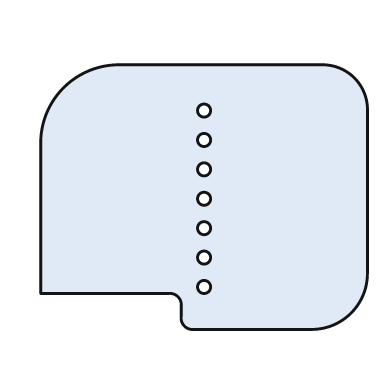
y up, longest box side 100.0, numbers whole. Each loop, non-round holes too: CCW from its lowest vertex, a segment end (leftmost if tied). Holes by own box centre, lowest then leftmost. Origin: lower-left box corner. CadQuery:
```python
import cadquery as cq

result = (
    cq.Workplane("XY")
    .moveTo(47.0, 0.0)
    .lineTo(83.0, 0.0)
    .threePointArc((95.0, 5.0), (100.0, 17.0))
    .lineTo(100.0, 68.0)
    .threePointArc((96.0, 77.0), (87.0, 81.0))
    .lineTo(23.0, 81.0)
    .threePointArc((7.0, 74.0), (0.0, 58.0))
    .lineTo(0.0, 11.0)
    .lineTo(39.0, 11.0)
    .threePointArc((42.0, 10.0), (43.0, 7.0))
    .lineTo(43.0, 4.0)
    .threePointArc((44.0, 1.0), (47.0, 0.0))
    .close()
    .moveTo(50.0, 13.0)
    .circle(2.0)
    .moveTo(50.0, 22.0)
    .circle(2.0)
    .moveTo(50.0, 31.0)
    .circle(2.0)
    .moveTo(50.0, 40.0)
    .circle(2.0)
    .moveTo(50.0, 49.0)
    .circle(2.0)
    .moveTo(50.0, 58.0)
    .circle(2.0)
    .moveTo(50.0, 67.0)
    .circle(2.0)
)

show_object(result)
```